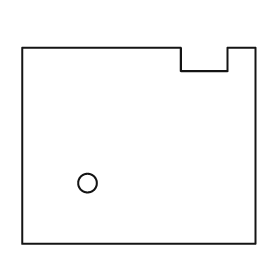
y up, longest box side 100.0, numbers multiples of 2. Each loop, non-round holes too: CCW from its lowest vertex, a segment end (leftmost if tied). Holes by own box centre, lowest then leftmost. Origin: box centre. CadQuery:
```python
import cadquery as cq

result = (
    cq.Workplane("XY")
    .moveTo(-50.0, -42.0)
    .lineTo(50.0, -42.0)
    .lineTo(50.0, 42.0)
    .lineTo(38.0, 42.0)
    .lineTo(38.0, 32.0)
    .lineTo(18.0, 32.0)
    .lineTo(18.0, 42.0)
    .lineTo(-50.0, 42.0)
    .close()
    .moveTo(-22.0, -16.0)
    .circle(4.0)
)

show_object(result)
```